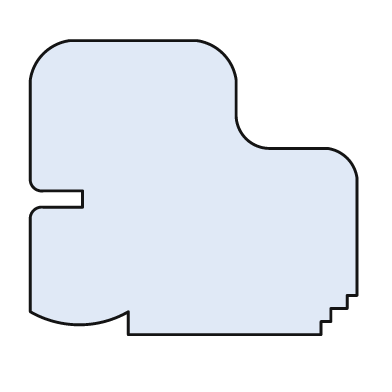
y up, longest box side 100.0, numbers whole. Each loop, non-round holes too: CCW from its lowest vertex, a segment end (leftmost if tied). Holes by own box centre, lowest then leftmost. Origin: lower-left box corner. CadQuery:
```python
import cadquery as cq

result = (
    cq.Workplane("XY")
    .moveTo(30.0, 0.0)
    .lineTo(89.0, 0.0)
    .lineTo(89.0, 4.0)
    .lineTo(92.0, 4.0)
    .lineTo(92.0, 8.0)
    .lineTo(97.0, 8.0)
    .lineTo(97.0, 12.0)
    .lineTo(100.0, 12.0)
    .lineTo(100.0, 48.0)
    .threePointArc((97.0, 54.0), (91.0, 57.0))
    .lineTo(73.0, 57.0)
    .threePointArc((66.0, 60.0), (63.0, 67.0))
    .lineTo(63.0, 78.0)
    .threePointArc((59.0, 86.0), (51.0, 90.0))
    .lineTo(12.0, 90.0)
    .threePointArc((4.0, 86.0), (0.0, 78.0))
    .lineTo(0.0, 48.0)
    .threePointArc((1.0, 45.0), (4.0, 44.0))
    .lineTo(16.0, 44.0)
    .lineTo(16.0, 39.0)
    .lineTo(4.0, 39.0)
    .threePointArc((1.0, 38.0), (0.0, 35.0))
    .lineTo(0.0, 7.0)
    .threePointArc((15.0, 3.0), (30.0, 7.0))
    .close()
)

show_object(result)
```